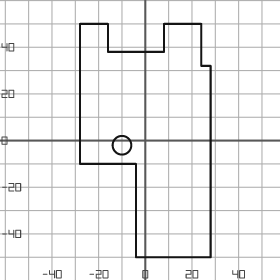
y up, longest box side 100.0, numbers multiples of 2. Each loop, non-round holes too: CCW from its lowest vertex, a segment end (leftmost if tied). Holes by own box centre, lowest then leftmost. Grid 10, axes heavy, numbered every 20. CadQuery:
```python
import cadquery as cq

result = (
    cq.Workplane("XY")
    .moveTo(-4.0, -50.0)
    .lineTo(28.0, -50.0)
    .lineTo(28.0, 32.0)
    .lineTo(24.0, 32.0)
    .lineTo(24.0, 50.0)
    .lineTo(8.0, 50.0)
    .lineTo(8.0, 38.0)
    .lineTo(-16.0, 38.0)
    .lineTo(-16.0, 50.0)
    .lineTo(-28.0, 50.0)
    .lineTo(-28.0, -10.0)
    .lineTo(-4.0, -10.0)
    .close()
    .moveTo(-10.0, -2.0)
    .circle(4.0)
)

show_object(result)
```